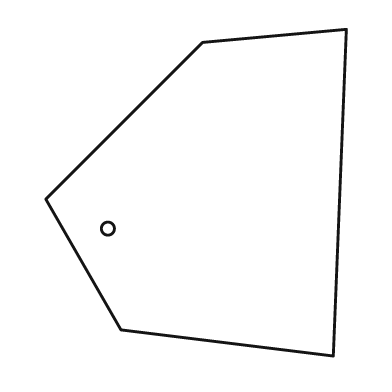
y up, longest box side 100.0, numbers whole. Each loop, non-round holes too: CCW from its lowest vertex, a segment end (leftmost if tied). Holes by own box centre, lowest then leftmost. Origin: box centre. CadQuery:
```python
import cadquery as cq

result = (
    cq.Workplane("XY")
    .moveTo(42.0, -50.0)
    .lineTo(46.0, 50.0)
    .lineTo(2.0, 46.0)
    .lineTo(-46.0, -2.0)
    .lineTo(-23.0, -42.0)
    .close()
    .moveTo(-27.0, -11.0)
    .circle(2.0)
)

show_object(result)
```